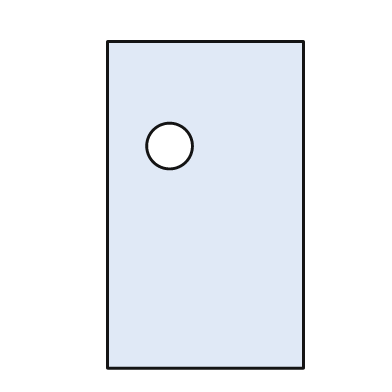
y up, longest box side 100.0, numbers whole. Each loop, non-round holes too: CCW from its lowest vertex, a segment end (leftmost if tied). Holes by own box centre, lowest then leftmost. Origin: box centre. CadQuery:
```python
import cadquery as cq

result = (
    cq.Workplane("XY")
    .moveTo(-30.0, -50.0)
    .lineTo(30.0, -50.0)
    .lineTo(30.0, 50.0)
    .lineTo(-30.0, 50.0)
    .close()
    .moveTo(-11.0, 18.0)
    .circle(7.0)
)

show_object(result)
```